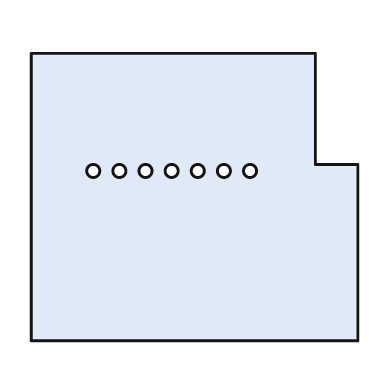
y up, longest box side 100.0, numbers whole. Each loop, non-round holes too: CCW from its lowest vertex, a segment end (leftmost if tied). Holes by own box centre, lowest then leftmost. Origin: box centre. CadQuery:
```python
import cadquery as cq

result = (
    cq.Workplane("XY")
    .moveTo(-50.0, -44.0)
    .lineTo(50.0, -44.0)
    .lineTo(50.0, 10.0)
    .lineTo(37.0, 10.0)
    .lineTo(37.0, 44.0)
    .lineTo(-50.0, 44.0)
    .close()
    .moveTo(-31.0, 8.0)
    .circle(2.0)
    .moveTo(-23.0, 8.0)
    .circle(2.0)
    .moveTo(-15.0, 8.0)
    .circle(2.0)
    .moveTo(-7.0, 8.0)
    .circle(2.0)
    .moveTo(1.0, 8.0)
    .circle(2.0)
    .moveTo(9.0, 8.0)
    .circle(2.0)
    .moveTo(17.0, 8.0)
    .circle(2.0)
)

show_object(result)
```